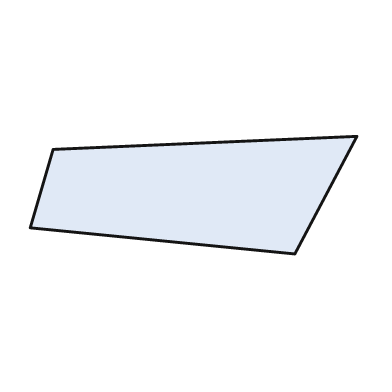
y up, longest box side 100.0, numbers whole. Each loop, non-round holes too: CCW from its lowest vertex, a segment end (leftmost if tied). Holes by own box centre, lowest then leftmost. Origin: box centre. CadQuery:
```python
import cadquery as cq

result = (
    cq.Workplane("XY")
    .moveTo(31.0, -18.0)
    .lineTo(50.0, 18.0)
    .lineTo(-43.0, 14.0)
    .lineTo(-50.0, -10.0)
    .close()
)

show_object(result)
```